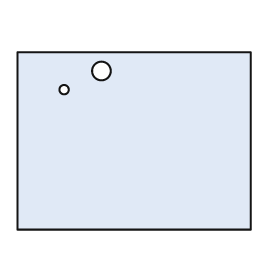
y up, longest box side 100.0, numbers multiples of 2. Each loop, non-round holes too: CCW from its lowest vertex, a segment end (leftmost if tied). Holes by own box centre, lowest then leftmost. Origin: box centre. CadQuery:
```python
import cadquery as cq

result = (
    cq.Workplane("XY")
    .moveTo(-50.0, -38.0)
    .lineTo(50.0, -38.0)
    .lineTo(50.0, 38.0)
    .lineTo(-50.0, 38.0)
    .close()
    .moveTo(-30.0, 22.0)
    .circle(2.0)
    .moveTo(-14.0, 30.0)
    .circle(4.0)
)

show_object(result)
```